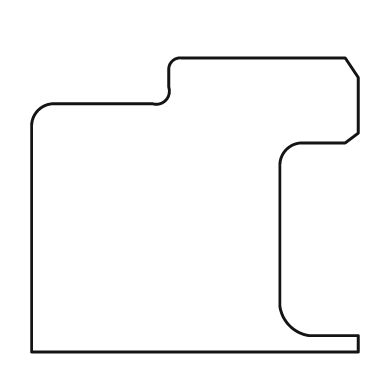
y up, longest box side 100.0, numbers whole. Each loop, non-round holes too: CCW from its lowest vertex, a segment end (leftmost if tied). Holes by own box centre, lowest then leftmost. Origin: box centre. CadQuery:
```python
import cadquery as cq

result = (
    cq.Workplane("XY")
    .moveTo(-50.0, -45.0)
    .lineTo(50.0, -45.0)
    .lineTo(50.0, -40.0)
    .lineTo(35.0, -40.0)
    .threePointArc((29.0, -37.0), (26.0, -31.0))
    .lineTo(26.0, 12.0)
    .threePointArc((28.0, 17.0), (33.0, 19.0))
    .lineTo(46.0, 19.0)
    .lineTo(50.0, 22.0)
    .lineTo(50.0, 39.0)
    .lineTo(46.0, 45.0)
    .lineTo(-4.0, 45.0)
    .threePointArc((-7.0, 44.0), (-8.0, 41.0))
    .lineTo(-8.0, 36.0)
    .threePointArc((-9.0, 32.0), (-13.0, 31.0))
    .lineTo(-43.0, 31.0)
    .threePointArc((-48.0, 29.0), (-50.0, 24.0))
    .close()
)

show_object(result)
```